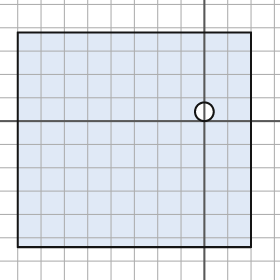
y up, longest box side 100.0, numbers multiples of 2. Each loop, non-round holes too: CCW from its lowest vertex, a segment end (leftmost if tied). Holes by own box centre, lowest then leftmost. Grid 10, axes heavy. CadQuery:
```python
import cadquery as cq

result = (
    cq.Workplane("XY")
    .moveTo(-80.0, -54.0)
    .lineTo(20.0, -54.0)
    .lineTo(20.0, 38.0)
    .lineTo(-80.0, 38.0)
    .close()
    .moveTo(0.0, 4.0)
    .circle(4.0)
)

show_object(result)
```